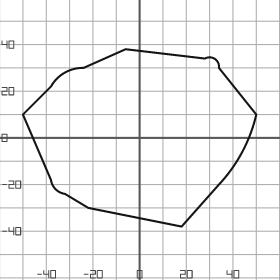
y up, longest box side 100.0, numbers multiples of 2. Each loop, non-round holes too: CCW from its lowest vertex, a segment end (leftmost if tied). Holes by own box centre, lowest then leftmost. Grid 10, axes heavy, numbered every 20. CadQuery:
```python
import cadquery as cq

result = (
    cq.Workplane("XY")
    .moveTo(18.0, -38.0)
    .lineTo(34.0, -20.0)
    .threePointArc((44.0, -6.0), (50.0, 10.0))
    .lineTo(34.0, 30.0)
    .threePointArc((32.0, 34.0), (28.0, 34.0))
    .lineTo(-6.0, 38.0)
    .lineTo(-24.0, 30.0)
    .threePointArc((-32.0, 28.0), (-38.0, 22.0))
    .lineTo(-50.0, 10.0)
    .lineTo(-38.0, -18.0)
    .threePointArc((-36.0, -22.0), (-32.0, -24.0))
    .lineTo(-22.0, -30.0)
    .close()
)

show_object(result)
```